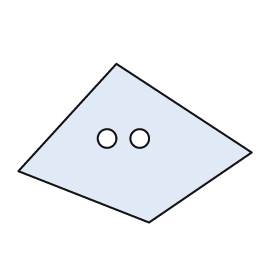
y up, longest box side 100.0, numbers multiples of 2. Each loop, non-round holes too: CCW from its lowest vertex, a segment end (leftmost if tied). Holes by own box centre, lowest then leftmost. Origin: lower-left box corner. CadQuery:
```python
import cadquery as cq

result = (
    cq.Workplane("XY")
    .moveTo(56.0, 0.0)
    .lineTo(100.0, 30.0)
    .lineTo(42.0, 68.0)
    .lineTo(0.0, 22.0)
    .close()
    .moveTo(38.0, 36.0)
    .circle(4.0)
    .moveTo(52.0, 36.0)
    .circle(4.0)
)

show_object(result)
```